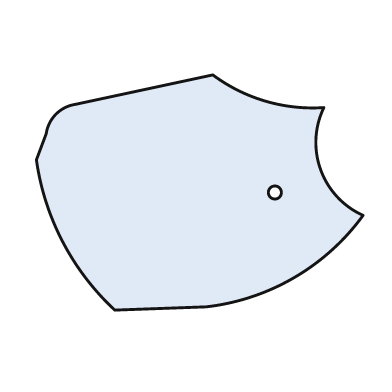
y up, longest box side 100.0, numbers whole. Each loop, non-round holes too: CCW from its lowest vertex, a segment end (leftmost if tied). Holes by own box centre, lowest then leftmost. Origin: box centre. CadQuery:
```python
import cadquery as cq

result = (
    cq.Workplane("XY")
    .moveTo(-26.0, -36.0)
    .lineTo(2.0, -35.0)
    .threePointArc((29.0, -26.0), (50.0, -7.0))
    .threePointArc((37.0, 7.0), (38.0, 26.0))
    .threePointArc((20.0, 28.0), (4.0, 36.0))
    .lineTo(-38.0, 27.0)
    .threePointArc((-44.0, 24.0), (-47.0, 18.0))
    .lineTo(-50.0, 10.0)
    .threePointArc((-42.0, -15.0), (-26.0, -36.0))
    .close()
    .moveTo(23.0, 0.0)
    .circle(2.0)
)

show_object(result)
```